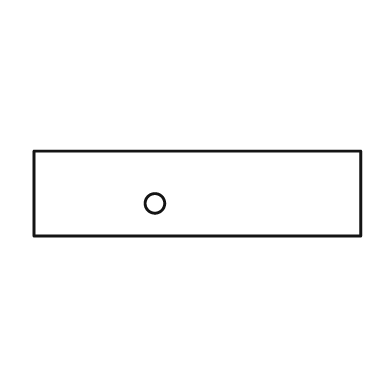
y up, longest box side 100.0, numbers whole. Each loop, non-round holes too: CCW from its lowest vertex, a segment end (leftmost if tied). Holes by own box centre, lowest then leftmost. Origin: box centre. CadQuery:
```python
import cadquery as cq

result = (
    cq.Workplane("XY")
    .moveTo(-50.0, -13.0)
    .lineTo(50.0, -13.0)
    .lineTo(50.0, 13.0)
    .lineTo(-50.0, 13.0)
    .close()
    .moveTo(-13.0, -3.0)
    .circle(3.0)
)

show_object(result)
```